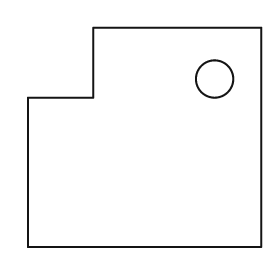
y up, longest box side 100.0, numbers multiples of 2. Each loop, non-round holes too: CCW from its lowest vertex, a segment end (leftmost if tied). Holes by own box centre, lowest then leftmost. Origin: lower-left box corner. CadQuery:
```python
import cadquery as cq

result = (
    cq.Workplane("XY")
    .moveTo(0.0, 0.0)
    .lineTo(100.0, 0.0)
    .lineTo(100.0, 94.0)
    .lineTo(28.0, 94.0)
    .lineTo(28.0, 64.0)
    .lineTo(0.0, 64.0)
    .close()
    .moveTo(80.0, 72.0)
    .circle(8.0)
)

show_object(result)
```